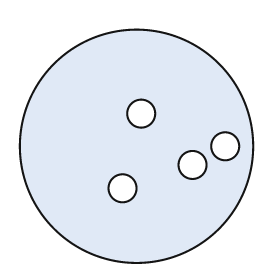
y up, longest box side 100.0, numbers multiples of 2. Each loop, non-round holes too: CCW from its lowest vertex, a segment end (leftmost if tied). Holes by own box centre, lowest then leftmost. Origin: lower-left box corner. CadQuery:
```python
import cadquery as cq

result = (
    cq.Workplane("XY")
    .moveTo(50.0, 50.0)
    .circle(50.0)
    .moveTo(44.0, 32.0)
    .circle(6.0)
    .moveTo(74.0, 42.0)
    .circle(6.0)
    .moveTo(88.0, 50.0)
    .circle(6.0)
    .moveTo(52.0, 64.0)
    .circle(6.0)
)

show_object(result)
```